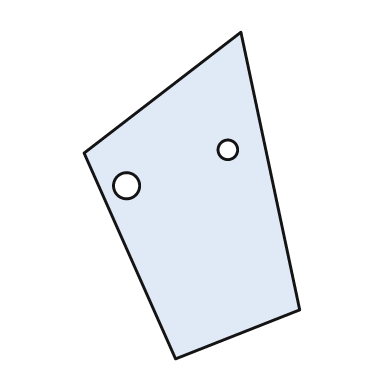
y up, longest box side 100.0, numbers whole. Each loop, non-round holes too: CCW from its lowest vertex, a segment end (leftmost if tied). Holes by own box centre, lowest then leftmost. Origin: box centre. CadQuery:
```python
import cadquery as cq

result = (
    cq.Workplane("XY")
    .moveTo(-5.0, -50.0)
    .lineTo(33.0, -35.0)
    .lineTo(15.0, 50.0)
    .lineTo(-33.0, 13.0)
    .close()
    .moveTo(-20.0, 3.0)
    .circle(4.0)
    .moveTo(11.0, 14.0)
    .circle(3.0)
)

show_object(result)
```